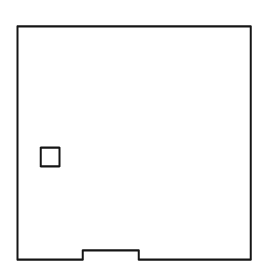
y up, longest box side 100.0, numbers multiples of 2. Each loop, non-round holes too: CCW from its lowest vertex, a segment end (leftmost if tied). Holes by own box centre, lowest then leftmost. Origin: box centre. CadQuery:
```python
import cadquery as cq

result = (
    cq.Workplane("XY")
    .moveTo(-50.0, -50.0)
    .lineTo(-22.0, -50.0)
    .lineTo(-22.0, -46.0)
    .lineTo(2.0, -46.0)
    .lineTo(2.0, -50.0)
    .lineTo(50.0, -50.0)
    .lineTo(50.0, 50.0)
    .lineTo(-50.0, 50.0)
    .close()
    .moveTo(-40.0, -10.0)
    .lineTo(-32.0, -10.0)
    .lineTo(-32.0, -2.0)
    .lineTo(-40.0, -2.0)
    .close()
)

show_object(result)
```